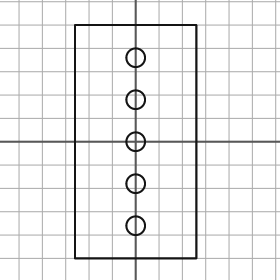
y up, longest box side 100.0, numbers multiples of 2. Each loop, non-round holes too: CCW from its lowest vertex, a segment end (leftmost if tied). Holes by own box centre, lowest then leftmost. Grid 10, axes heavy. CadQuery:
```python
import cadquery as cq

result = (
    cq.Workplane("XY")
    .moveTo(-26.0, -50.0)
    .lineTo(26.0, -50.0)
    .lineTo(26.0, 50.0)
    .lineTo(-26.0, 50.0)
    .close()
    .moveTo(0.0, -36.0)
    .circle(4.0)
    .moveTo(0.0, -18.0)
    .circle(4.0)
    .moveTo(0.0, 0.0)
    .circle(4.0)
    .moveTo(0.0, 18.0)
    .circle(4.0)
    .moveTo(0.0, 36.0)
    .circle(4.0)
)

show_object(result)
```